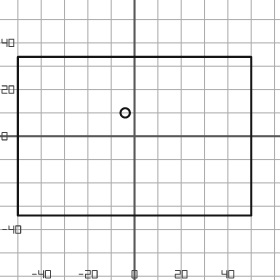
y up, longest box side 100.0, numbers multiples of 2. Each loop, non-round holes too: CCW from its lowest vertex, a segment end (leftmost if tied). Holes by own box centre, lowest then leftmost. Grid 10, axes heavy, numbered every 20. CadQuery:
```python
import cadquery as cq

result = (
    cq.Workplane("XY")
    .moveTo(-50.0, -34.0)
    .lineTo(50.0, -34.0)
    .lineTo(50.0, 34.0)
    .lineTo(-50.0, 34.0)
    .close()
    .moveTo(-4.0, 10.0)
    .circle(2.0)
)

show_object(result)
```